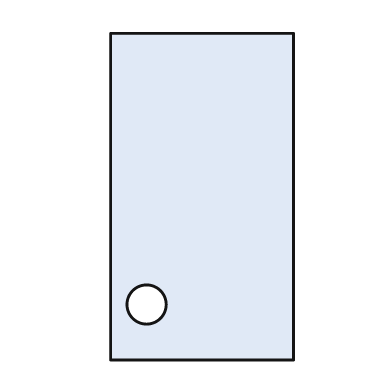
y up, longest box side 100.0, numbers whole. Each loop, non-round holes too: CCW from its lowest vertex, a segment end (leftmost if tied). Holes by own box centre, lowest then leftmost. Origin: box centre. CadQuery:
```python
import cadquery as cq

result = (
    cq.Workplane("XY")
    .moveTo(-28.0, -50.0)
    .lineTo(28.0, -50.0)
    .lineTo(28.0, 50.0)
    .lineTo(-28.0, 50.0)
    .close()
    .moveTo(-17.0, -33.0)
    .circle(6.0)
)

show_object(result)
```